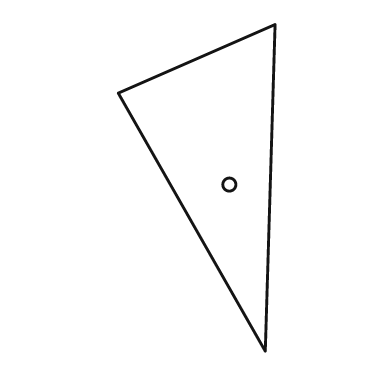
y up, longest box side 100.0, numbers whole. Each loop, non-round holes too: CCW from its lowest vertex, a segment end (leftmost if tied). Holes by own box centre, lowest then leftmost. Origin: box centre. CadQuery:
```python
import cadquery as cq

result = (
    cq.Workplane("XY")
    .moveTo(21.0, -50.0)
    .lineTo(24.0, 50.0)
    .lineTo(-24.0, 29.0)
    .close()
    .moveTo(10.0, 1.0)
    .circle(2.0)
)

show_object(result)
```